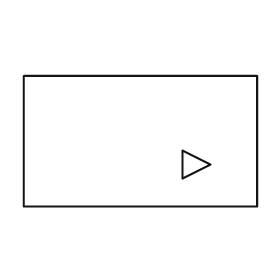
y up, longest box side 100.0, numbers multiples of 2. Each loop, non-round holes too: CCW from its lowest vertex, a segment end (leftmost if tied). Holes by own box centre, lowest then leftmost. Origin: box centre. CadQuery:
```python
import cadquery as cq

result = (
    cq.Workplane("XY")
    .moveTo(-50.0, -28.0)
    .lineTo(50.0, -28.0)
    .lineTo(50.0, 28.0)
    .lineTo(-50.0, 28.0)
    .close()
    .moveTo(18.0, -16.0)
    .lineTo(30.0, -10.0)
    .lineTo(18.0, -4.0)
    .close()
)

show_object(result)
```